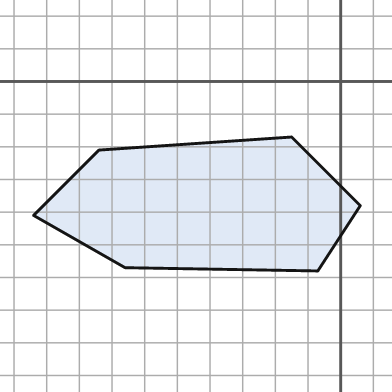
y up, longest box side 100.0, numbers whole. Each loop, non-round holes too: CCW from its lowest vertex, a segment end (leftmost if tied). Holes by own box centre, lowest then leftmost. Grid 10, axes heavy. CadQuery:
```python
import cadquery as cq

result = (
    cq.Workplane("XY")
    .moveTo(-7.0, -58.0)
    .lineTo(6.0, -38.0)
    .lineTo(-15.0, -17.0)
    .lineTo(-74.0, -21.0)
    .lineTo(-94.0, -41.0)
    .lineTo(-66.0, -57.0)
    .close()
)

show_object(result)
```